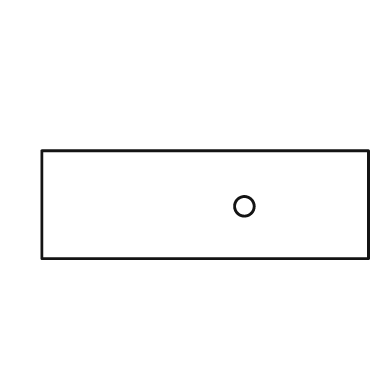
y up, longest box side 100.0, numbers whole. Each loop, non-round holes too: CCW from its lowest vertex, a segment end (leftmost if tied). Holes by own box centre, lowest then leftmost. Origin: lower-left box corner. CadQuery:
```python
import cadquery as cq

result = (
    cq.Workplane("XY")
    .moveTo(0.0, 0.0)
    .lineTo(100.0, 0.0)
    .lineTo(100.0, 33.0)
    .lineTo(0.0, 33.0)
    .close()
    .moveTo(62.0, 16.0)
    .circle(3.0)
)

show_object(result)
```